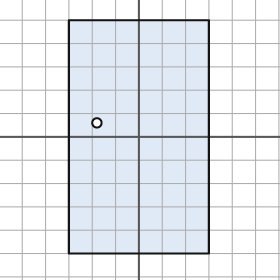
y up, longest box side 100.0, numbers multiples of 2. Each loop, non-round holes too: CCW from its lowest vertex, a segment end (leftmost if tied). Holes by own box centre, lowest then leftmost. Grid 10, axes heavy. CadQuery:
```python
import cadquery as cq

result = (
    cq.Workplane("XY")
    .moveTo(-30.0, -50.0)
    .lineTo(30.0, -50.0)
    .lineTo(30.0, 50.0)
    .lineTo(-30.0, 50.0)
    .close()
    .moveTo(-18.0, 6.0)
    .circle(2.0)
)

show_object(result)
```